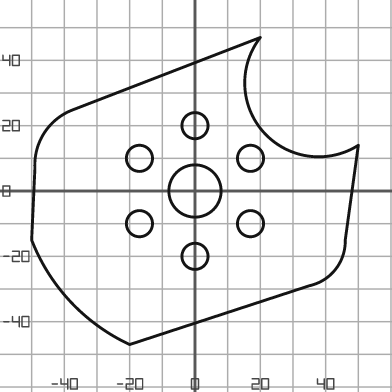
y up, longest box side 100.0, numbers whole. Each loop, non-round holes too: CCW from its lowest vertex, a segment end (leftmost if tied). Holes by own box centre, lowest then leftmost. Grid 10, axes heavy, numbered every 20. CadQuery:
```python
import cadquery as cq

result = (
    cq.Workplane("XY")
    .moveTo(-20.0, -47.0)
    .lineTo(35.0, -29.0)
    .threePointArc((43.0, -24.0), (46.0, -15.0))
    .lineTo(50.0, 14.0)
    .threePointArc((21.0, 18.0), (20.0, 47.0))
    .lineTo(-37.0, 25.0)
    .threePointArc((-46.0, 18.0), (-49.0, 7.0))
    .lineTo(-50.0, -15.0)
    .threePointArc((-38.0, -34.0), (-20.0, -47.0))
    .close()
    .moveTo(0.0, -20.0)
    .circle(4.0)
    .moveTo(-17.0, -10.0)
    .circle(4.0)
    .moveTo(17.0, -10.0)
    .circle(4.0)
    .moveTo(0.0, 0.0)
    .circle(8.0)
    .moveTo(-17.0, 10.0)
    .circle(4.0)
    .moveTo(17.0, 10.0)
    .circle(4.0)
    .moveTo(0.0, 20.0)
    .circle(4.0)
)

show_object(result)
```